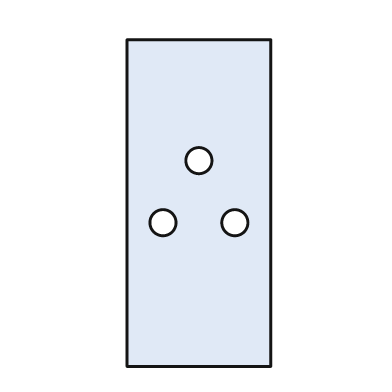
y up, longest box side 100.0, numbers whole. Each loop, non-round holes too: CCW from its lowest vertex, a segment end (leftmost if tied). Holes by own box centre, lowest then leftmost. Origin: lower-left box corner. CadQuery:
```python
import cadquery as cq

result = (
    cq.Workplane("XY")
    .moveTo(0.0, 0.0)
    .lineTo(44.0, 0.0)
    .lineTo(44.0, 100.0)
    .lineTo(0.0, 100.0)
    .close()
    .moveTo(11.0, 44.0)
    .circle(4.0)
    .moveTo(33.0, 44.0)
    .circle(4.0)
    .moveTo(22.0, 63.0)
    .circle(4.0)
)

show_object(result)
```